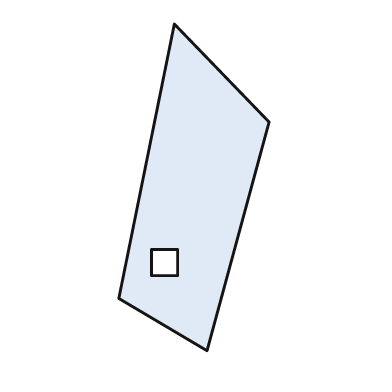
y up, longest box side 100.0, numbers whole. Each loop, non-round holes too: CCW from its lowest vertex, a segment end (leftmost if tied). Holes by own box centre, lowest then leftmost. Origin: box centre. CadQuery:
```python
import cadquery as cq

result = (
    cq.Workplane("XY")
    .moveTo(4.0, -50.0)
    .lineTo(23.0, 20.0)
    .lineTo(-6.0, 50.0)
    .lineTo(-23.0, -34.0)
    .close()
    .moveTo(-13.0, -27.0)
    .lineTo(-5.0, -27.0)
    .lineTo(-5.0, -19.0)
    .lineTo(-13.0, -19.0)
    .close()
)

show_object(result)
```